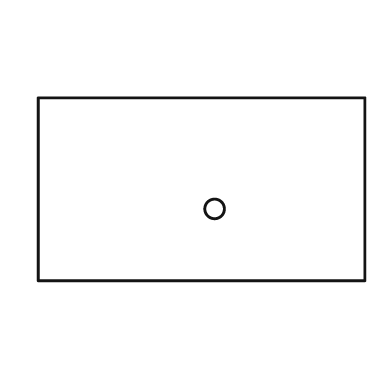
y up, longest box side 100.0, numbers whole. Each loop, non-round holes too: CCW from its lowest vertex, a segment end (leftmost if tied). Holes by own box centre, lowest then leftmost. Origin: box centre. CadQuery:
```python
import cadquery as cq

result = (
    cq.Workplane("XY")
    .moveTo(-50.0, -28.0)
    .lineTo(50.0, -28.0)
    .lineTo(50.0, 28.0)
    .lineTo(-50.0, 28.0)
    .close()
    .moveTo(4.0, -6.0)
    .circle(3.0)
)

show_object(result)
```